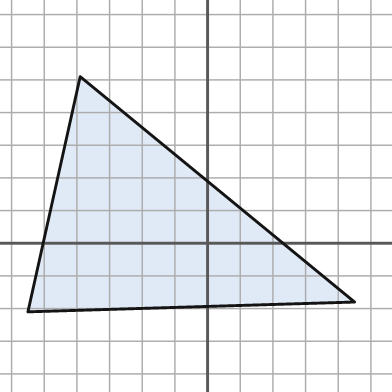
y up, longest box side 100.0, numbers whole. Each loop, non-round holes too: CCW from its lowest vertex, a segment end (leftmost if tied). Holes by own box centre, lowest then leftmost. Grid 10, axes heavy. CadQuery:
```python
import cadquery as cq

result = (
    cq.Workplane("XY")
    .moveTo(-55.0, -21.0)
    .lineTo(45.0, -18.0)
    .lineTo(-39.0, 51.0)
    .close()
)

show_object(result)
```